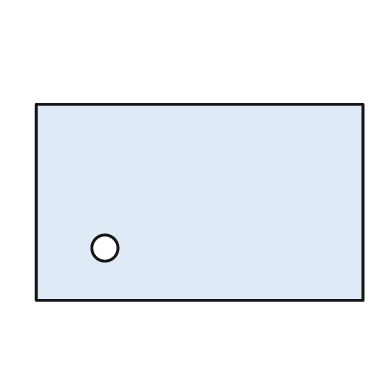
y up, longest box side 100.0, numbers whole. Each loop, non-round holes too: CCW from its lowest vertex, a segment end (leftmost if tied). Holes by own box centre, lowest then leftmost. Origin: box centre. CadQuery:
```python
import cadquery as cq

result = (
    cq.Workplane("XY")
    .moveTo(-50.0, -30.0)
    .lineTo(50.0, -30.0)
    .lineTo(50.0, 30.0)
    .lineTo(-50.0, 30.0)
    .close()
    .moveTo(-29.0, -14.0)
    .circle(4.0)
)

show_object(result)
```